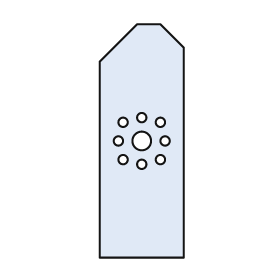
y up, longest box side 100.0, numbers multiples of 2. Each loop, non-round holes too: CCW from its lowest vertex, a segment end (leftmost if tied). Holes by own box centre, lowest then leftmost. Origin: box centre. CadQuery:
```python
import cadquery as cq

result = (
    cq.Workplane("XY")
    .moveTo(-18.0, -50.0)
    .lineTo(18.0, -50.0)
    .lineTo(18.0, 40.0)
    .lineTo(8.0, 50.0)
    .lineTo(-2.0, 50.0)
    .lineTo(-18.0, 34.0)
    .close()
    .moveTo(0.0, -10.0)
    .circle(2.0)
    .moveTo(-8.0, -8.0)
    .circle(2.0)
    .moveTo(8.0, -8.0)
    .circle(2.0)
    .moveTo(-10.0, 0.0)
    .circle(2.0)
    .moveTo(0.0, 0.0)
    .circle(4.0)
    .moveTo(10.0, 0.0)
    .circle(2.0)
    .moveTo(-8.0, 8.0)
    .circle(2.0)
    .moveTo(8.0, 8.0)
    .circle(2.0)
    .moveTo(0.0, 10.0)
    .circle(2.0)
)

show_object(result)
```